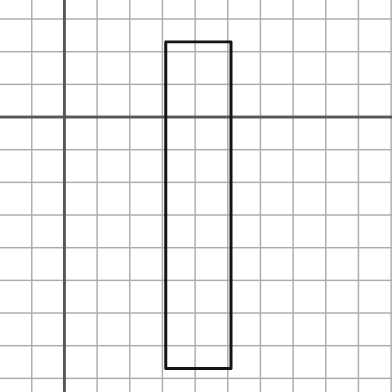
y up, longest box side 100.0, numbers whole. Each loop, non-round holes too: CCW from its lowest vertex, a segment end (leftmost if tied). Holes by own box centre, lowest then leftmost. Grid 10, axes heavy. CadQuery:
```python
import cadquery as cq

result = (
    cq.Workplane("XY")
    .moveTo(31.0, -77.0)
    .lineTo(51.0, -77.0)
    .lineTo(51.0, 23.0)
    .lineTo(31.0, 23.0)
    .close()
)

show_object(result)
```